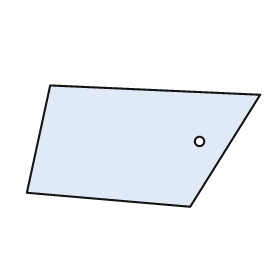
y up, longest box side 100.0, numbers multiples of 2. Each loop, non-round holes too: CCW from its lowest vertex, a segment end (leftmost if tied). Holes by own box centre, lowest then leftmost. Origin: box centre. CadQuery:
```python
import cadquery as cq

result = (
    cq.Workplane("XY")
    .moveTo(20.0, -26.0)
    .lineTo(50.0, 22.0)
    .lineTo(-40.0, 26.0)
    .lineTo(-50.0, -20.0)
    .close()
    .moveTo(24.0, 2.0)
    .circle(2.0)
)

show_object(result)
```